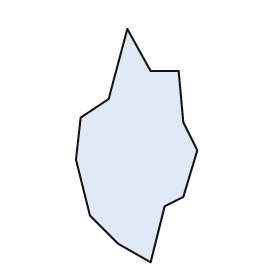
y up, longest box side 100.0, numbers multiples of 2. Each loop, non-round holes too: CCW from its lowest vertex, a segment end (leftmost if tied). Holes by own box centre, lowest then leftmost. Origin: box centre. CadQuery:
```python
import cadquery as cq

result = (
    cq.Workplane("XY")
    .moveTo(6.0, -50.0)
    .lineTo(12.0, -26.0)
    .lineTo(20.0, -22.0)
    .lineTo(26.0, -2.0)
    .lineTo(20.0, 10.0)
    .lineTo(18.0, 32.0)
    .lineTo(6.0, 32.0)
    .lineTo(-4.0, 50.0)
    .lineTo(-12.0, 20.0)
    .lineTo(-24.0, 12.0)
    .lineTo(-26.0, -6.0)
    .lineTo(-20.0, -30.0)
    .lineTo(-8.0, -42.0)
    .close()
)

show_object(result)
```